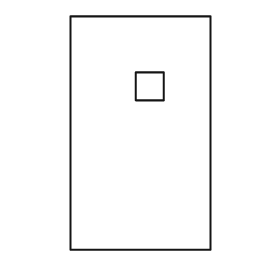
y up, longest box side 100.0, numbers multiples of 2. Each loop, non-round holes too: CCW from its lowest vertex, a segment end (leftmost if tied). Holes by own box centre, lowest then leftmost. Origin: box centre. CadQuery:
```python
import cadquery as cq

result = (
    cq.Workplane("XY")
    .moveTo(-30.0, -50.0)
    .lineTo(30.0, -50.0)
    .lineTo(30.0, 50.0)
    .lineTo(-30.0, 50.0)
    .close()
    .moveTo(-2.0, 14.0)
    .lineTo(10.0, 14.0)
    .lineTo(10.0, 26.0)
    .lineTo(-2.0, 26.0)
    .close()
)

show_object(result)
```